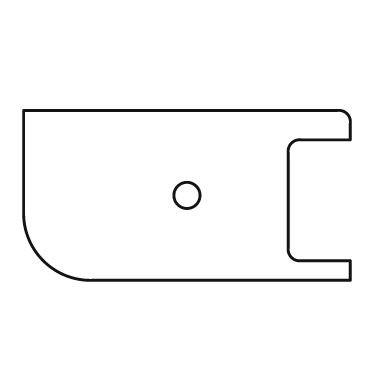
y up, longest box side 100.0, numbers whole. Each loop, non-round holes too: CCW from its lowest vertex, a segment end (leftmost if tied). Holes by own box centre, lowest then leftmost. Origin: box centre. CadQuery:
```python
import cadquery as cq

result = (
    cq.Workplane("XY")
    .moveTo(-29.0, -26.0)
    .lineTo(50.0, -26.0)
    .lineTo(50.0, -20.0)
    .lineTo(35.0, -20.0)
    .threePointArc((32.0, -19.0), (31.0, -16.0))
    .lineTo(31.0, 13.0)
    .threePointArc((32.0, 16.0), (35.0, 17.0))
    .lineTo(50.0, 17.0)
    .lineTo(50.0, 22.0)
    .threePointArc((49.0, 25.0), (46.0, 26.0))
    .lineTo(-50.0, 26.0)
    .lineTo(-50.0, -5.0)
    .threePointArc((-44.0, -20.0), (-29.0, -26.0))
    .close()
    .moveTo(0.0, 0.0)
    .circle(4.0)
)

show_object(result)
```